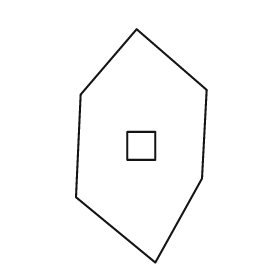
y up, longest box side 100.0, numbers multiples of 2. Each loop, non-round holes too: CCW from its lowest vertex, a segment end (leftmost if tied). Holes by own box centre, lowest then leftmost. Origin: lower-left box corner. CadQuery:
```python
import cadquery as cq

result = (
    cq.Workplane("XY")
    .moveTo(34.0, 0.0)
    .lineTo(54.0, 36.0)
    .lineTo(56.0, 74.0)
    .lineTo(26.0, 100.0)
    .lineTo(2.0, 72.0)
    .lineTo(0.0, 28.0)
    .close()
    .moveTo(22.0, 44.0)
    .lineTo(34.0, 44.0)
    .lineTo(34.0, 56.0)
    .lineTo(22.0, 56.0)
    .close()
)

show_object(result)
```